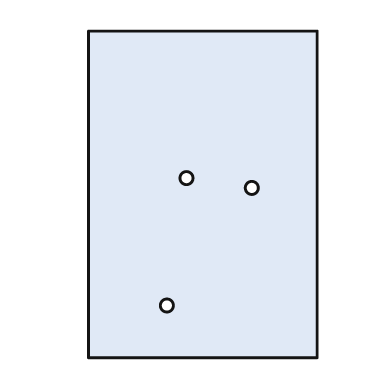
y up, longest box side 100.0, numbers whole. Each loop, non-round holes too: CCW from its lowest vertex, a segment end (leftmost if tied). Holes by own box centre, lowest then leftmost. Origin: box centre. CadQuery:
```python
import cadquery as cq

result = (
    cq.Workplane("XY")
    .moveTo(-35.0, -50.0)
    .lineTo(35.0, -50.0)
    .lineTo(35.0, 50.0)
    .lineTo(-35.0, 50.0)
    .close()
    .moveTo(-11.0, -34.0)
    .circle(2.0)
    .moveTo(15.0, 2.0)
    .circle(2.0)
    .moveTo(-5.0, 5.0)
    .circle(2.0)
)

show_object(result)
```